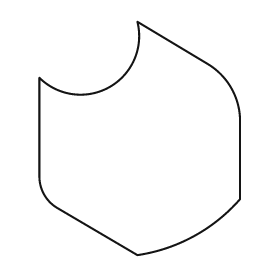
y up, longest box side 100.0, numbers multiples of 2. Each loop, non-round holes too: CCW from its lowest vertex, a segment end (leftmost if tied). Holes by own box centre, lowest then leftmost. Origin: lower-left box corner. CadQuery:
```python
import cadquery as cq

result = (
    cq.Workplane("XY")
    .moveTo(42.0, 0.0)
    .threePointArc((66.0, 8.0), (86.0, 24.0))
    .lineTo(86.0, 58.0)
    .threePointArc((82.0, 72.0), (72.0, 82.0))
    .lineTo(42.0, 100.0)
    .threePointArc((30.0, 72.0), (0.0, 76.0))
    .lineTo(0.0, 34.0)
    .threePointArc((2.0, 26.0), (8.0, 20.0))
    .close()
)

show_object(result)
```